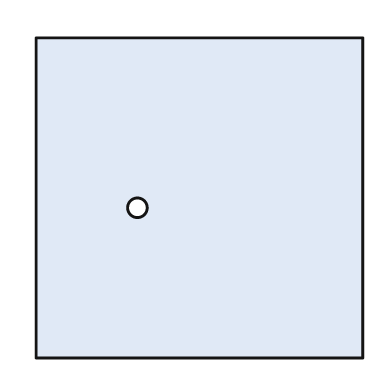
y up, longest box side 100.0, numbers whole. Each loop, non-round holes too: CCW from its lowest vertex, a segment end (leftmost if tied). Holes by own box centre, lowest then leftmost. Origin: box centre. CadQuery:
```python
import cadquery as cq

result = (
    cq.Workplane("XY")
    .moveTo(-50.0, -49.0)
    .lineTo(50.0, -49.0)
    .lineTo(50.0, 49.0)
    .lineTo(-50.0, 49.0)
    .close()
    .moveTo(-19.0, -3.0)
    .circle(3.0)
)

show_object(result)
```